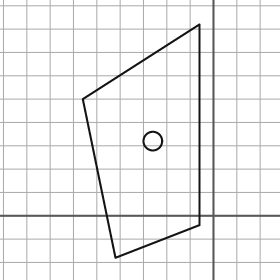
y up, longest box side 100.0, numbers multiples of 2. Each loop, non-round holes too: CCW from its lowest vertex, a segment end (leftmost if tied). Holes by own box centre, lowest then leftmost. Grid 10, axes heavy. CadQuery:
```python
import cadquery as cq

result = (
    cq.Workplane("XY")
    .moveTo(-42.0, -18.0)
    .lineTo(-6.0, -4.0)
    .lineTo(-6.0, 82.0)
    .lineTo(-56.0, 50.0)
    .close()
    .moveTo(-26.0, 32.0)
    .circle(4.0)
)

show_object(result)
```